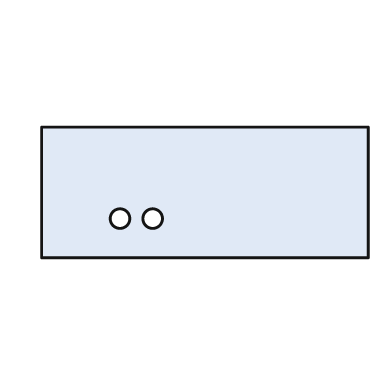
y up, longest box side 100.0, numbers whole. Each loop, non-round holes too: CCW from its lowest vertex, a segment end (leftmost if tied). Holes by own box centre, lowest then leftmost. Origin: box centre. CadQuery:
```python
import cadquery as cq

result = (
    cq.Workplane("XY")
    .moveTo(-50.0, -20.0)
    .lineTo(50.0, -20.0)
    .lineTo(50.0, 20.0)
    .lineTo(-50.0, 20.0)
    .close()
    .moveTo(-26.0, -8.0)
    .circle(3.0)
    .moveTo(-16.0, -8.0)
    .circle(3.0)
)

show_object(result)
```